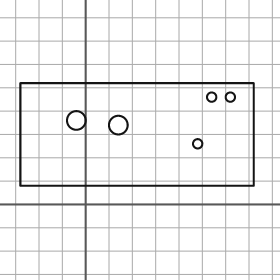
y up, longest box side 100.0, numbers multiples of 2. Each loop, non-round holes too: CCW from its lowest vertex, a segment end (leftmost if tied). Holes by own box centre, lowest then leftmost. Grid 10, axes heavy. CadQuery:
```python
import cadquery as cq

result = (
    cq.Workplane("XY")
    .moveTo(-28.0, 8.0)
    .lineTo(72.0, 8.0)
    .lineTo(72.0, 52.0)
    .lineTo(-28.0, 52.0)
    .close()
    .moveTo(48.0, 26.0)
    .circle(2.0)
    .moveTo(14.0, 34.0)
    .circle(4.0)
    .moveTo(-4.0, 36.0)
    .circle(4.0)
    .moveTo(54.0, 46.0)
    .circle(2.0)
    .moveTo(62.0, 46.0)
    .circle(2.0)
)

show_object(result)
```